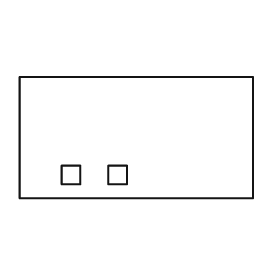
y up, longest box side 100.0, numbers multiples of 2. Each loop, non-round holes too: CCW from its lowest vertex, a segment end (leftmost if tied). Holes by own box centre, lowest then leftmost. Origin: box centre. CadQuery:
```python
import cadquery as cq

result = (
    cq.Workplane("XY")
    .moveTo(-50.0, -26.0)
    .lineTo(50.0, -26.0)
    .lineTo(50.0, 26.0)
    .lineTo(-50.0, 26.0)
    .close()
    .moveTo(-32.0, -20.0)
    .lineTo(-24.0, -20.0)
    .lineTo(-24.0, -12.0)
    .lineTo(-32.0, -12.0)
    .close()
    .moveTo(-12.0, -20.0)
    .lineTo(-4.0, -20.0)
    .lineTo(-4.0, -12.0)
    .lineTo(-12.0, -12.0)
    .close()
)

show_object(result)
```